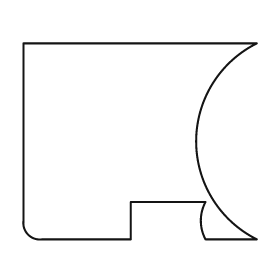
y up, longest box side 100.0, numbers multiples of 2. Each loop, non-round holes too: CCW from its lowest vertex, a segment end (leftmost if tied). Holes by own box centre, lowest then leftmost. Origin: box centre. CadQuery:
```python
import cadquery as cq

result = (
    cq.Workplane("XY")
    .moveTo(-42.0, -42.0)
    .lineTo(-4.0, -42.0)
    .lineTo(-4.0, -26.0)
    .lineTo(28.0, -26.0)
    .threePointArc((26.0, -34.0), (28.0, -42.0))
    .lineTo(50.0, -42.0)
    .threePointArc((24.0, 0.0), (50.0, 42.0))
    .lineTo(-50.0, 42.0)
    .lineTo(-50.0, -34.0)
    .threePointArc((-48.0, -40.0), (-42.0, -42.0))
    .close()
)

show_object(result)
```